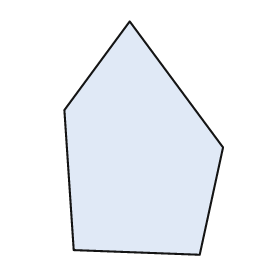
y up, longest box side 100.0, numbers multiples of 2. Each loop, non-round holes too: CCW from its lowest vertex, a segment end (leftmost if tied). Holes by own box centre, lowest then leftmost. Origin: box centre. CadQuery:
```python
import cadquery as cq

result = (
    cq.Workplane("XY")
    .moveTo(24.0, -50.0)
    .lineTo(34.0, -4.0)
    .lineTo(-6.0, 50.0)
    .lineTo(-34.0, 12.0)
    .lineTo(-30.0, -48.0)
    .close()
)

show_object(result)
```